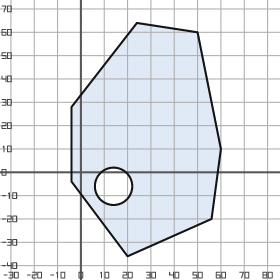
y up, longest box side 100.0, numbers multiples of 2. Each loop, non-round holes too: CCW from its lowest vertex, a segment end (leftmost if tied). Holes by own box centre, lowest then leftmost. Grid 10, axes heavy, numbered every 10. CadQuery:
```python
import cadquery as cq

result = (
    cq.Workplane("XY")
    .moveTo(20.0, -36.0)
    .lineTo(56.0, -20.0)
    .lineTo(60.0, 10.0)
    .lineTo(50.0, 60.0)
    .lineTo(24.0, 64.0)
    .lineTo(-4.0, 28.0)
    .lineTo(-4.0, -4.0)
    .close()
    .moveTo(14.0, -6.0)
    .circle(8.0)
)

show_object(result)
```